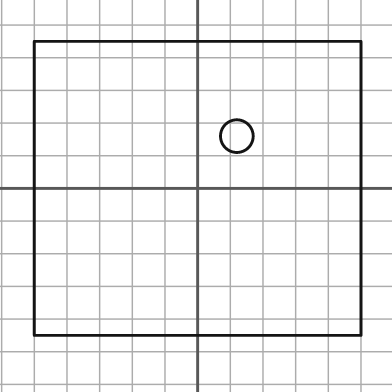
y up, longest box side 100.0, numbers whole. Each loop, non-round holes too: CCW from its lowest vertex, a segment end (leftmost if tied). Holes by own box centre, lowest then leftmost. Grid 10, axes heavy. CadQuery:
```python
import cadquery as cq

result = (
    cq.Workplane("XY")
    .moveTo(-50.0, -45.0)
    .lineTo(50.0, -45.0)
    .lineTo(50.0, 45.0)
    .lineTo(-50.0, 45.0)
    .close()
    .moveTo(12.0, 16.0)
    .circle(5.0)
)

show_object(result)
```